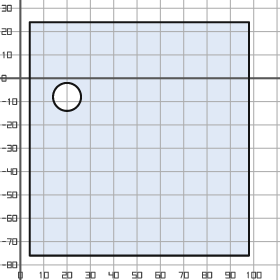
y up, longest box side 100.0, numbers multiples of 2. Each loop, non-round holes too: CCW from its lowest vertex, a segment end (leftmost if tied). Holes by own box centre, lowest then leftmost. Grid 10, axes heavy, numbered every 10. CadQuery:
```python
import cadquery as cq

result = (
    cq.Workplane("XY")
    .moveTo(4.0, -76.0)
    .lineTo(98.0, -76.0)
    .lineTo(98.0, 24.0)
    .lineTo(4.0, 24.0)
    .close()
    .moveTo(20.0, -8.0)
    .circle(6.0)
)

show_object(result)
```